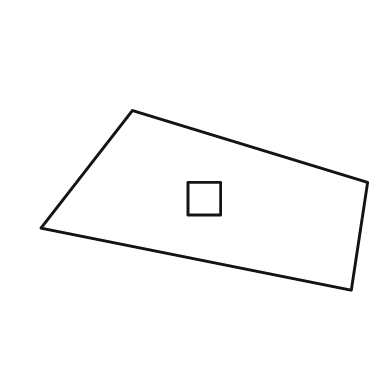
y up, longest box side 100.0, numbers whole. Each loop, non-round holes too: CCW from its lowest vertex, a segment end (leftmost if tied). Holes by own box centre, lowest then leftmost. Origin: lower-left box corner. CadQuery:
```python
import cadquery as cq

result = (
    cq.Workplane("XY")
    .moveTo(95.0, 0.0)
    .lineTo(100.0, 33.0)
    .lineTo(28.0, 55.0)
    .lineTo(0.0, 19.0)
    .close()
    .moveTo(45.0, 23.0)
    .lineTo(55.0, 23.0)
    .lineTo(55.0, 33.0)
    .lineTo(45.0, 33.0)
    .close()
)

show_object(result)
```